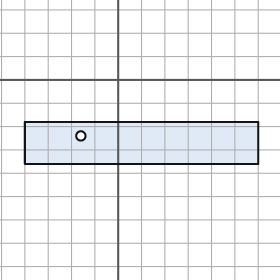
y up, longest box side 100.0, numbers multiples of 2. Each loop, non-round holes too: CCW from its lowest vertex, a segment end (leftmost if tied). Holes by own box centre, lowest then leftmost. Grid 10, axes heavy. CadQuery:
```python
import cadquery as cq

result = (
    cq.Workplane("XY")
    .moveTo(-40.0, -36.0)
    .lineTo(60.0, -36.0)
    .lineTo(60.0, -18.0)
    .lineTo(-40.0, -18.0)
    .close()
    .moveTo(-16.0, -24.0)
    .circle(2.0)
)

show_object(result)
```